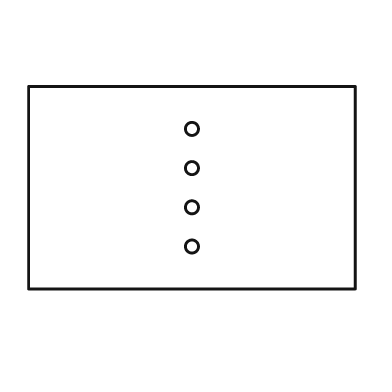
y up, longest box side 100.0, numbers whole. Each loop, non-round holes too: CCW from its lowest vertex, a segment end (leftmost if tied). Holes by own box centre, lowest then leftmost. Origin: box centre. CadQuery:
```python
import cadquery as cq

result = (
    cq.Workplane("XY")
    .moveTo(-50.0, -31.0)
    .lineTo(50.0, -31.0)
    .lineTo(50.0, 31.0)
    .lineTo(-50.0, 31.0)
    .close()
    .moveTo(0.0, -18.0)
    .circle(2.0)
    .moveTo(0.0, -6.0)
    .circle(2.0)
    .moveTo(0.0, 6.0)
    .circle(2.0)
    .moveTo(0.0, 18.0)
    .circle(2.0)
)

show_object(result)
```